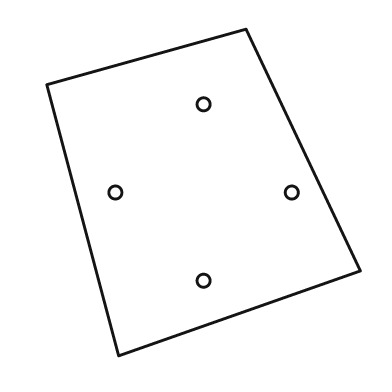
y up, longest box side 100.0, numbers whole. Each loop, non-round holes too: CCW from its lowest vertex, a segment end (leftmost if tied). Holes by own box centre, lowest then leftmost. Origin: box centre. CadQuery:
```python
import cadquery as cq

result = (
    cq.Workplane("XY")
    .moveTo(-26.0, -50.0)
    .lineTo(48.0, -24.0)
    .lineTo(13.0, 50.0)
    .lineTo(-48.0, 33.0)
    .close()
    .moveTo(0.0, -27.0)
    .circle(2.0)
    .moveTo(-27.0, 0.0)
    .circle(2.0)
    .moveTo(27.0, 0.0)
    .circle(2.0)
    .moveTo(0.0, 27.0)
    .circle(2.0)
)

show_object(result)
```